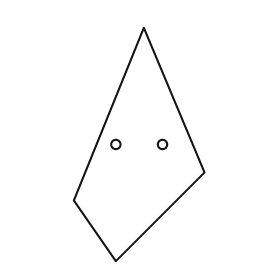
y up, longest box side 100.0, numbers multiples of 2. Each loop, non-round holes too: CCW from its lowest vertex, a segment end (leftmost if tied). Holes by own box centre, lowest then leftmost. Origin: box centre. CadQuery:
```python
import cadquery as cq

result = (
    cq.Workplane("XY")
    .moveTo(-10.0, -50.0)
    .lineTo(28.0, -12.0)
    .lineTo(2.0, 50.0)
    .lineTo(-28.0, -24.0)
    .close()
    .moveTo(-10.0, 0.0)
    .circle(2.0)
    .moveTo(10.0, 0.0)
    .circle(2.0)
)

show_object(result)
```